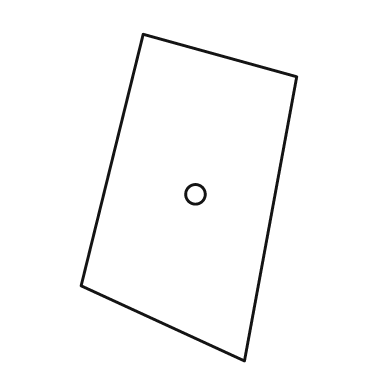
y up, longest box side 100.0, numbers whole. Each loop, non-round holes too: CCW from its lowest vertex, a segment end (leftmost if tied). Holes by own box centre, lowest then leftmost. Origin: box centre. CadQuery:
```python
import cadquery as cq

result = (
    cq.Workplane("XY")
    .moveTo(17.0, -50.0)
    .lineTo(33.0, 37.0)
    .lineTo(-14.0, 50.0)
    .lineTo(-33.0, -27.0)
    .close()
    .moveTo(2.0, 1.0)
    .circle(3.0)
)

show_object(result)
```